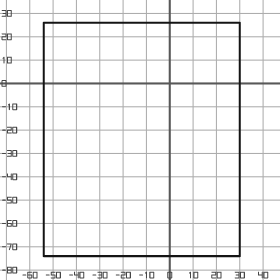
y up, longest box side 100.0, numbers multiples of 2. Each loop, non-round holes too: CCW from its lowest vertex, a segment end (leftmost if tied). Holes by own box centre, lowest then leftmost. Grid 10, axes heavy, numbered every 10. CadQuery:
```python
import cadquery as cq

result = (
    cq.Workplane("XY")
    .moveTo(-54.0, -74.0)
    .lineTo(30.0, -74.0)
    .lineTo(30.0, 26.0)
    .lineTo(-54.0, 26.0)
    .close()
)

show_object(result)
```